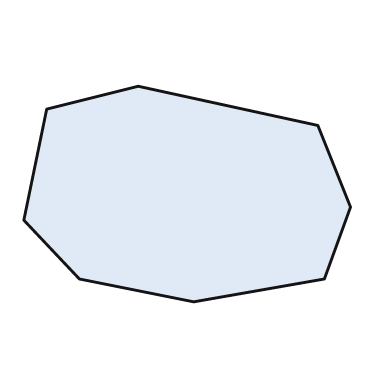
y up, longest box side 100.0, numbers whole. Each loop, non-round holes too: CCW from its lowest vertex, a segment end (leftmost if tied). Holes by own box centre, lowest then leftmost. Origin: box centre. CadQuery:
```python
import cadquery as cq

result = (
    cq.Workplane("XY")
    .moveTo(2.0, -33.0)
    .lineTo(42.0, -26.0)
    .lineTo(50.0, -4.0)
    .lineTo(40.0, 21.0)
    .lineTo(-15.0, 33.0)
    .lineTo(-43.0, 26.0)
    .lineTo(-50.0, -8.0)
    .lineTo(-33.0, -26.0)
    .close()
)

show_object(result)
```